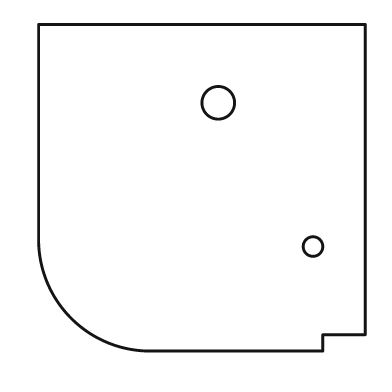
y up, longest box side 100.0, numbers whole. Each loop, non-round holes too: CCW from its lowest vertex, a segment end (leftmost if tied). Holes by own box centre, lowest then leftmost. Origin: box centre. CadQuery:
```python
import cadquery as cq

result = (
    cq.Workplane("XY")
    .moveTo(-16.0, -50.0)
    .lineTo(37.0, -50.0)
    .lineTo(37.0, -45.0)
    .lineTo(50.0, -45.0)
    .lineTo(50.0, 50.0)
    .lineTo(-50.0, 50.0)
    .lineTo(-50.0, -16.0)
    .threePointArc((-40.0, -40.0), (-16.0, -50.0))
    .close()
    .moveTo(34.0, -18.0)
    .circle(3.0)
    .moveTo(5.0, 26.0)
    .circle(5.0)
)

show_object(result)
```